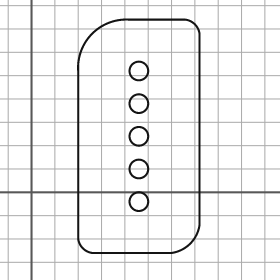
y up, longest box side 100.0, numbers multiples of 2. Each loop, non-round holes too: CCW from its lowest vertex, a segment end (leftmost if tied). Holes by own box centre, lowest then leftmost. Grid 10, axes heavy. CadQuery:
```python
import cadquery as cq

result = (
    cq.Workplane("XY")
    .moveTo(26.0, -26.0)
    .lineTo(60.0, -26.0)
    .threePointArc((68.0, -22.0), (72.0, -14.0))
    .lineTo(72.0, 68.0)
    .threePointArc((70.0, 72.0), (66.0, 74.0))
    .lineTo(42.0, 74.0)
    .threePointArc((26.0, 68.0), (20.0, 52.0))
    .lineTo(20.0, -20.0)
    .threePointArc((22.0, -24.0), (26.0, -26.0))
    .close()
    .moveTo(46.0, -4.0)
    .circle(4.0)
    .moveTo(46.0, 10.0)
    .circle(4.0)
    .moveTo(46.0, 24.0)
    .circle(4.0)
    .moveTo(46.0, 38.0)
    .circle(4.0)
    .moveTo(46.0, 52.0)
    .circle(4.0)
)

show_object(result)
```